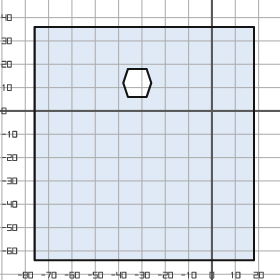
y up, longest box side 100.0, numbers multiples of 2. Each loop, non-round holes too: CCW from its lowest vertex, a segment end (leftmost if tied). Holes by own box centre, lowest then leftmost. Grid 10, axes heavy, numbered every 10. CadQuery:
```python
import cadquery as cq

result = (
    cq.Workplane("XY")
    .moveTo(-76.0, -64.0)
    .lineTo(18.0, -64.0)
    .lineTo(18.0, 36.0)
    .lineTo(-76.0, 36.0)
    .close()
    .moveTo(-36.0, 6.0)
    .lineTo(-28.0, 6.0)
    .lineTo(-26.0, 12.0)
    .lineTo(-28.0, 18.0)
    .lineTo(-36.0, 18.0)
    .lineTo(-38.0, 12.0)
    .close()
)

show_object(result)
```